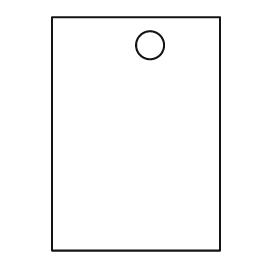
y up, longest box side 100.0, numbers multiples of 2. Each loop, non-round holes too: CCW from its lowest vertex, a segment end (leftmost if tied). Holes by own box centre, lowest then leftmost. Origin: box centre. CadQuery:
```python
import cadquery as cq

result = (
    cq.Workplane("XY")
    .moveTo(-36.0, -50.0)
    .lineTo(36.0, -50.0)
    .lineTo(36.0, 50.0)
    .lineTo(-36.0, 50.0)
    .close()
    .moveTo(6.0, 38.0)
    .circle(6.0)
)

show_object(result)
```